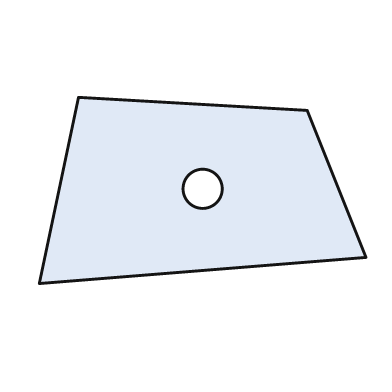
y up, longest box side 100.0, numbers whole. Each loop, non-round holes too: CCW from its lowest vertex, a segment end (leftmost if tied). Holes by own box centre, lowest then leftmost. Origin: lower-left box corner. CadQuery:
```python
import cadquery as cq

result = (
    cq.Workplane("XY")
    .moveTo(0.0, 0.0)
    .lineTo(100.0, 8.0)
    .lineTo(82.0, 53.0)
    .lineTo(12.0, 57.0)
    .close()
    .moveTo(50.0, 29.0)
    .circle(6.0)
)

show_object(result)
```